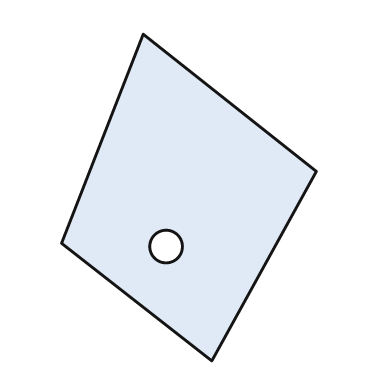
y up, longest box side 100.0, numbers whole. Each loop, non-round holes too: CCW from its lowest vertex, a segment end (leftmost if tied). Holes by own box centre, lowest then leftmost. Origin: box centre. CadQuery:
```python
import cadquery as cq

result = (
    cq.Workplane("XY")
    .moveTo(7.0, -50.0)
    .lineTo(39.0, 8.0)
    .lineTo(-14.0, 50.0)
    .lineTo(-39.0, -14.0)
    .close()
    .moveTo(-7.0, -15.0)
    .circle(5.0)
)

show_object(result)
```